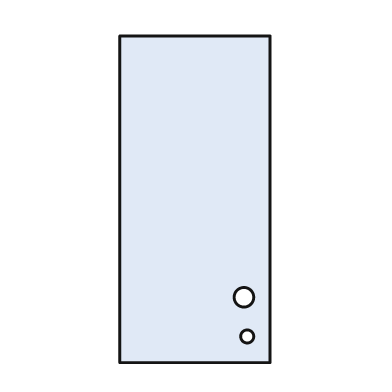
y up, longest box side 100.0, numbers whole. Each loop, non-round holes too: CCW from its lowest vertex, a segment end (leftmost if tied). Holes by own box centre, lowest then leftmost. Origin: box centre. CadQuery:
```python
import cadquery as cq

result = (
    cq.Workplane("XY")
    .moveTo(-23.0, -50.0)
    .lineTo(23.0, -50.0)
    .lineTo(23.0, 50.0)
    .lineTo(-23.0, 50.0)
    .close()
    .moveTo(16.0, -42.0)
    .circle(2.0)
    .moveTo(15.0, -30.0)
    .circle(3.0)
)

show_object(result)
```